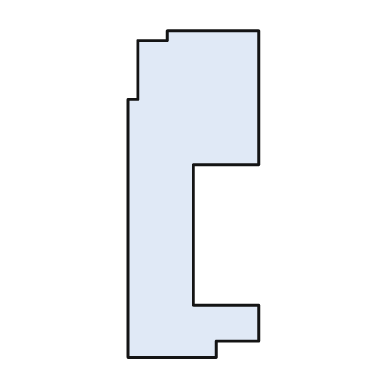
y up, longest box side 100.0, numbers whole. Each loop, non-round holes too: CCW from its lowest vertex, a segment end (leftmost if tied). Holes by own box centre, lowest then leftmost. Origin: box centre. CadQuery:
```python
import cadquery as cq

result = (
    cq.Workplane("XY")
    .moveTo(-20.0, -50.0)
    .lineTo(7.0, -50.0)
    .lineTo(7.0, -45.0)
    .lineTo(20.0, -45.0)
    .lineTo(20.0, -34.0)
    .lineTo(0.0, -34.0)
    .lineTo(0.0, 9.0)
    .lineTo(20.0, 9.0)
    .lineTo(20.0, 50.0)
    .lineTo(-8.0, 50.0)
    .lineTo(-8.0, 47.0)
    .lineTo(-17.0, 47.0)
    .lineTo(-17.0, 29.0)
    .lineTo(-20.0, 29.0)
    .close()
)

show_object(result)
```